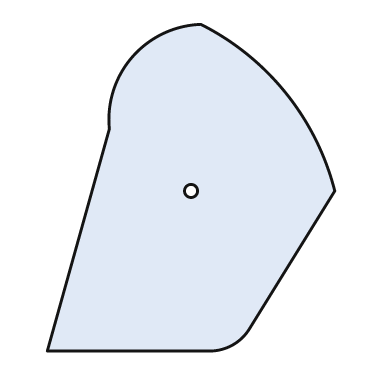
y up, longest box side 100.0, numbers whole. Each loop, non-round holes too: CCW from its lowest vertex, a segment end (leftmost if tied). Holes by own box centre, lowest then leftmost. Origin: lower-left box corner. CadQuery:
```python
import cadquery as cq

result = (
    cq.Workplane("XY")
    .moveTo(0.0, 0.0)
    .lineTo(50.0, 0.0)
    .threePointArc((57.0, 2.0), (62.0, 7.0))
    .lineTo(88.0, 49.0)
    .threePointArc((73.0, 79.0), (47.0, 100.0))
    .threePointArc((26.0, 90.0), (19.0, 68.0))
    .close()
    .moveTo(44.0, 49.0)
    .circle(2.0)
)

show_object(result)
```